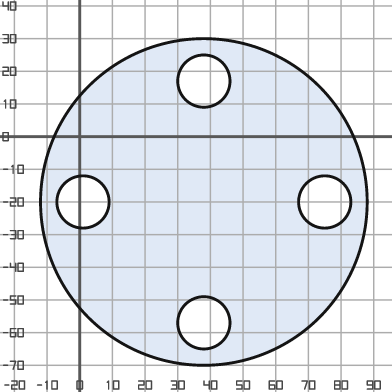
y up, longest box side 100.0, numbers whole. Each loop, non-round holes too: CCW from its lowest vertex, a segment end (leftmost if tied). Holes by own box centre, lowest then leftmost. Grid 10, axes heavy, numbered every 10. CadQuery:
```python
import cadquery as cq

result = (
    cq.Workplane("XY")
    .moveTo(38.0, -20.0)
    .circle(50.0)
    .moveTo(38.0, -57.0)
    .circle(8.0)
    .moveTo(1.0, -20.0)
    .circle(8.0)
    .moveTo(75.0, -20.0)
    .circle(8.0)
    .moveTo(38.0, 17.0)
    .circle(8.0)
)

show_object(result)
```